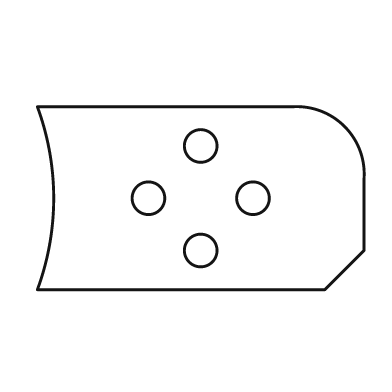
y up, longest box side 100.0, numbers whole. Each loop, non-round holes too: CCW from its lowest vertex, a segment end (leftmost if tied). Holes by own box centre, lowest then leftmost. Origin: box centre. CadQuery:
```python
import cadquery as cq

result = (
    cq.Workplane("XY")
    .moveTo(-50.0, -28.0)
    .lineTo(38.0, -28.0)
    .lineTo(50.0, -16.0)
    .lineTo(50.0, 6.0)
    .threePointArc((44.0, 22.0), (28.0, 28.0))
    .lineTo(-50.0, 28.0)
    .threePointArc((-45.0, 0.0), (-50.0, -28.0))
    .close()
    .moveTo(0.0, -16.0)
    .circle(5.0)
    .moveTo(-16.0, 0.0)
    .circle(5.0)
    .moveTo(16.0, 0.0)
    .circle(5.0)
    .moveTo(0.0, 16.0)
    .circle(5.0)
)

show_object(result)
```